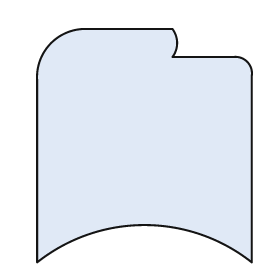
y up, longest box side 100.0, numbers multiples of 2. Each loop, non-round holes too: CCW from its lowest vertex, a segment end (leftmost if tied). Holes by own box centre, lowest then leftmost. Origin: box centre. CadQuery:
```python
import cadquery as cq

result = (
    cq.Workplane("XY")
    .moveTo(-46.0, -50.0)
    .threePointArc((0.0, -34.0), (46.0, -50.0))
    .lineTo(46.0, 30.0)
    .threePointArc((44.0, 36.0), (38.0, 38.0))
    .lineTo(12.0, 38.0)
    .threePointArc((14.0, 44.0), (12.0, 50.0))
    .lineTo(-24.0, 50.0)
    .threePointArc((-40.0, 44.0), (-46.0, 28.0))
    .close()
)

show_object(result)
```